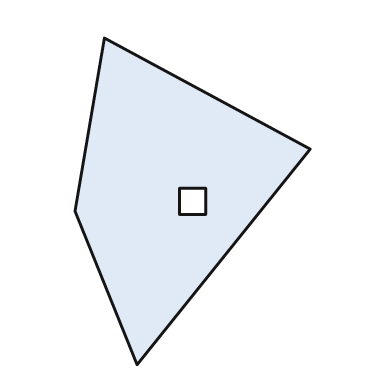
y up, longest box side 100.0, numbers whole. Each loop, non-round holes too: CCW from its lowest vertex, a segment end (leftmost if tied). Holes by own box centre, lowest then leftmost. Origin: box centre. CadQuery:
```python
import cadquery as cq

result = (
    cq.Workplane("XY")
    .moveTo(-17.0, -50.0)
    .lineTo(36.0, 16.0)
    .lineTo(-27.0, 50.0)
    .lineTo(-36.0, -3.0)
    .close()
    .moveTo(-4.0, -4.0)
    .lineTo(4.0, -4.0)
    .lineTo(4.0, 4.0)
    .lineTo(-4.0, 4.0)
    .close()
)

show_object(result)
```